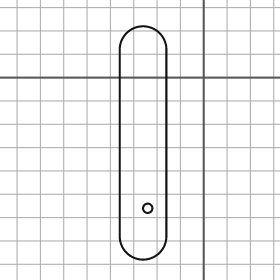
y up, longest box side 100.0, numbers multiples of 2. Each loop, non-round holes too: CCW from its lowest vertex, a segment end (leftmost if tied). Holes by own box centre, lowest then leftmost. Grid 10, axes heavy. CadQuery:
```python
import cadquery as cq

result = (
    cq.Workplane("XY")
    .moveTo(-36.0, -68.0)
    .threePointArc((-26.0, -78.0), (-16.0, -68.0))
    .lineTo(-16.0, 12.0)
    .threePointArc((-26.0, 22.0), (-36.0, 12.0))
    .close()
    .moveTo(-24.0, -56.0)
    .circle(2.0)
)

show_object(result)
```